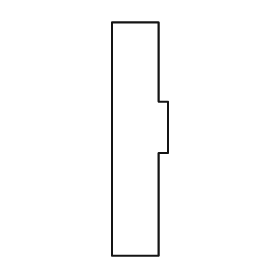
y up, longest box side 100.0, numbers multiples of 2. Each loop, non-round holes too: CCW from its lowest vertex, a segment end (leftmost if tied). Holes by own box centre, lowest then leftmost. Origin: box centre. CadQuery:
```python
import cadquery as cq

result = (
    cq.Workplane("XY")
    .moveTo(-12.0, -50.0)
    .lineTo(8.0, -50.0)
    .lineTo(8.0, -6.0)
    .lineTo(12.0, -6.0)
    .lineTo(12.0, 16.0)
    .lineTo(8.0, 16.0)
    .lineTo(8.0, 50.0)
    .lineTo(-12.0, 50.0)
    .close()
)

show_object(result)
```